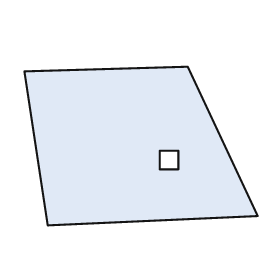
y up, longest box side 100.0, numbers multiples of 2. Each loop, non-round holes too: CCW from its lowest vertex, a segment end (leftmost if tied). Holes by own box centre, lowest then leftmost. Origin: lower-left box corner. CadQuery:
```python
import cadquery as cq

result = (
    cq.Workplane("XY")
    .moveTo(10.0, 0.0)
    .lineTo(100.0, 4.0)
    .lineTo(70.0, 68.0)
    .lineTo(0.0, 66.0)
    .close()
    .moveTo(58.0, 24.0)
    .lineTo(66.0, 24.0)
    .lineTo(66.0, 32.0)
    .lineTo(58.0, 32.0)
    .close()
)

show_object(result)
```